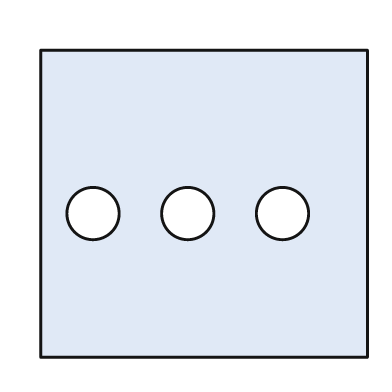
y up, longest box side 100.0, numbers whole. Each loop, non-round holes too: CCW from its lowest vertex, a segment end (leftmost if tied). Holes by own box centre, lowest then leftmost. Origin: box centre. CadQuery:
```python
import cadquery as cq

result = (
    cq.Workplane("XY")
    .moveTo(-50.0, -47.0)
    .lineTo(50.0, -47.0)
    .lineTo(50.0, 47.0)
    .lineTo(-50.0, 47.0)
    .close()
    .moveTo(-34.0, -3.0)
    .circle(8.0)
    .moveTo(-5.0, -3.0)
    .circle(8.0)
    .moveTo(24.0, -3.0)
    .circle(8.0)
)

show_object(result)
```